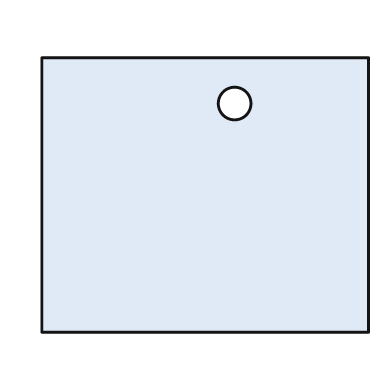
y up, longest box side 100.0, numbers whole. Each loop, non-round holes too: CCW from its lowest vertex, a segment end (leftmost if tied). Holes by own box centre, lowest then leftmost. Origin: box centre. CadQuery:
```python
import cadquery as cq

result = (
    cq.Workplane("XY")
    .moveTo(-50.0, -42.0)
    .lineTo(50.0, -42.0)
    .lineTo(50.0, 42.0)
    .lineTo(-50.0, 42.0)
    .close()
    .moveTo(9.0, 28.0)
    .circle(5.0)
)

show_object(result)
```